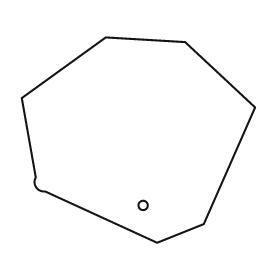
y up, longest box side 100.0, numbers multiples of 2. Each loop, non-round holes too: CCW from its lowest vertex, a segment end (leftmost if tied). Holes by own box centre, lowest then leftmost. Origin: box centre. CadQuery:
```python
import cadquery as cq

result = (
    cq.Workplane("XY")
    .moveTo(8.0, -44.0)
    .lineTo(28.0, -36.0)
    .lineTo(50.0, 14.0)
    .lineTo(20.0, 42.0)
    .lineTo(-14.0, 44.0)
    .lineTo(-50.0, 18.0)
    .lineTo(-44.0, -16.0)
    .threePointArc((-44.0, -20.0), (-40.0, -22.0))
    .close()
    .moveTo(2.0, -28.0)
    .circle(2.0)
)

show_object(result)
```